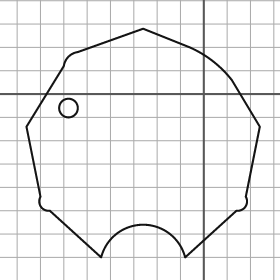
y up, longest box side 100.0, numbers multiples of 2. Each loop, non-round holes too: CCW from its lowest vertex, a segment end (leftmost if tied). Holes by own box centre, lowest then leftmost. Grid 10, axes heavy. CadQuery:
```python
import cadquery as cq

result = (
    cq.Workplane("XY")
    .moveTo(-44.0, -70.0)
    .threePointArc((-26.0, -56.0), (-8.0, -70.0))
    .lineTo(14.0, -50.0)
    .threePointArc((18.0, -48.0), (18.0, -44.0))
    .lineTo(24.0, -14.0)
    .lineTo(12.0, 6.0)
    .threePointArc((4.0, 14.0), (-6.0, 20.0))
    .lineTo(-26.0, 28.0)
    .lineTo(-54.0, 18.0)
    .threePointArc((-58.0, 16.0), (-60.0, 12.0))
    .lineTo(-76.0, -14.0)
    .lineTo(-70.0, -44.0)
    .threePointArc((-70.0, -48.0), (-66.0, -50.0))
    .close()
    .moveTo(-58.0, -6.0)
    .circle(4.0)
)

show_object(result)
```